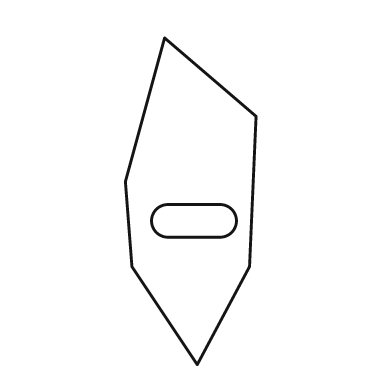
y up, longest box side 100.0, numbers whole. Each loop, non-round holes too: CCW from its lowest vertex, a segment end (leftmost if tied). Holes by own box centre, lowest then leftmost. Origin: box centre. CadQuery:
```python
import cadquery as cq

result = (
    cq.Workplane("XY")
    .moveTo(2.0, -50.0)
    .lineTo(18.0, -20.0)
    .lineTo(20.0, 26.0)
    .lineTo(-8.0, 50.0)
    .lineTo(-20.0, 6.0)
    .lineTo(-18.0, -20.0)
    .close()
    .moveTo(-7.0, -11.0)
    .lineTo(9.0, -11.0)
    .threePointArc((14.0, -6.0), (9.0, -1.0))
    .lineTo(-7.0, -1.0)
    .threePointArc((-12.0, -6.0), (-7.0, -11.0))
    .close()
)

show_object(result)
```